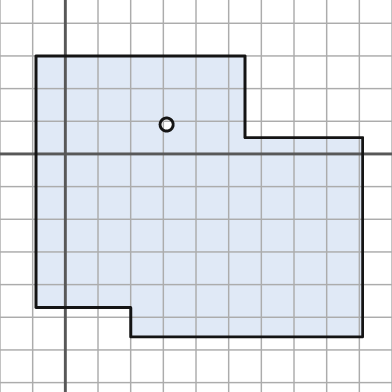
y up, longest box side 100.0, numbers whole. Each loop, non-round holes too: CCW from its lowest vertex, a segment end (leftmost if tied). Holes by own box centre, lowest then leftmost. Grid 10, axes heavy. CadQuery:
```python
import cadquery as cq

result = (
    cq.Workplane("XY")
    .moveTo(20.0, -56.0)
    .lineTo(91.0, -56.0)
    .lineTo(91.0, 5.0)
    .lineTo(55.0, 5.0)
    .lineTo(55.0, 30.0)
    .lineTo(-9.0, 30.0)
    .lineTo(-9.0, -47.0)
    .lineTo(20.0, -47.0)
    .close()
    .moveTo(31.0, 9.0)
    .circle(2.0)
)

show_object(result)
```